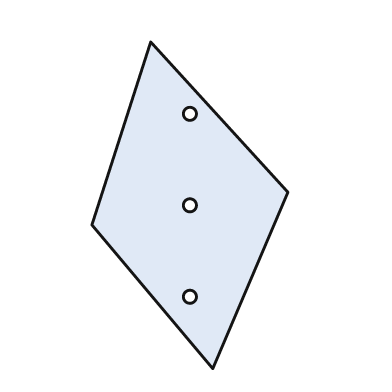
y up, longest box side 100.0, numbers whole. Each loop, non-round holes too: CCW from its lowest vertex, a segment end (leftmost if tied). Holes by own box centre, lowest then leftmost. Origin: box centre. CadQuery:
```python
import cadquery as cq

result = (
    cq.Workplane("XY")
    .moveTo(7.0, -50.0)
    .lineTo(30.0, 4.0)
    .lineTo(-12.0, 50.0)
    .lineTo(-30.0, -6.0)
    .close()
    .moveTo(0.0, -28.0)
    .circle(2.0)
    .moveTo(0.0, 0.0)
    .circle(2.0)
    .moveTo(0.0, 28.0)
    .circle(2.0)
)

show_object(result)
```